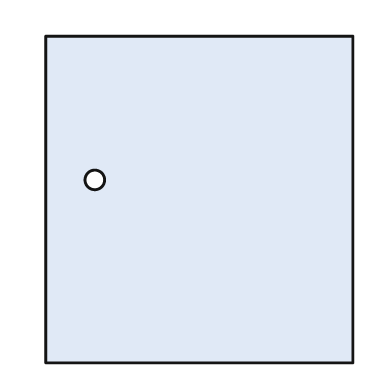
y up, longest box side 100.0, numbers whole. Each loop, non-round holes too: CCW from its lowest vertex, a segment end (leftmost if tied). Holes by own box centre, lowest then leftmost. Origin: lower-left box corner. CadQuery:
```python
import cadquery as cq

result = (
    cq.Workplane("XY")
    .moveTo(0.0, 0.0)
    .lineTo(94.0, 0.0)
    .lineTo(94.0, 100.0)
    .lineTo(0.0, 100.0)
    .close()
    .moveTo(15.0, 56.0)
    .circle(3.0)
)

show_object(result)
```